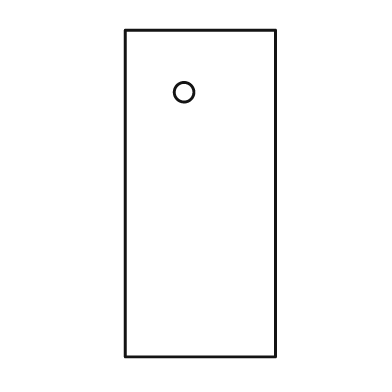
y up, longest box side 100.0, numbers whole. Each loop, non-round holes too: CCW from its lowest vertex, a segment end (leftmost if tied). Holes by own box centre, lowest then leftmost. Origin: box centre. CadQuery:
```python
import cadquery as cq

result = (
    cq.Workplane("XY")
    .moveTo(-23.0, -50.0)
    .lineTo(23.0, -50.0)
    .lineTo(23.0, 50.0)
    .lineTo(-23.0, 50.0)
    .close()
    .moveTo(-5.0, 31.0)
    .circle(3.0)
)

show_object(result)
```